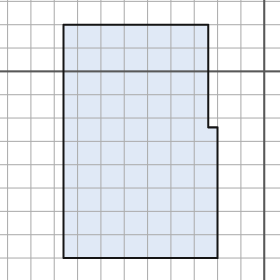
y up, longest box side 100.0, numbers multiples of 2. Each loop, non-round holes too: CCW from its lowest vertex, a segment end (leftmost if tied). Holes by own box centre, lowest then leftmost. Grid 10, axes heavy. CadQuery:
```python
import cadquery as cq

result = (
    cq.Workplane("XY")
    .moveTo(-86.0, -80.0)
    .lineTo(-20.0, -80.0)
    .lineTo(-20.0, -24.0)
    .lineTo(-24.0, -24.0)
    .lineTo(-24.0, 20.0)
    .lineTo(-86.0, 20.0)
    .close()
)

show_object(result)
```